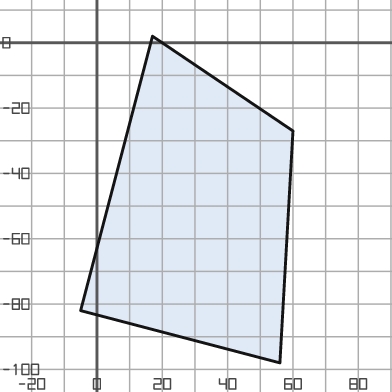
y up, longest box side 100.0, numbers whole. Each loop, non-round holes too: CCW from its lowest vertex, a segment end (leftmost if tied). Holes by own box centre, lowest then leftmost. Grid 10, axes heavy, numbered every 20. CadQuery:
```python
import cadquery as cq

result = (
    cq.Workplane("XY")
    .moveTo(56.0, -98.0)
    .lineTo(60.0, -27.0)
    .lineTo(17.0, 2.0)
    .lineTo(-5.0, -82.0)
    .close()
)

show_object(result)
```